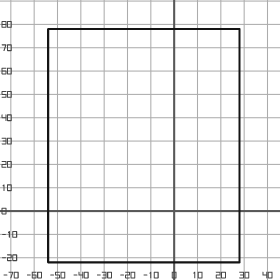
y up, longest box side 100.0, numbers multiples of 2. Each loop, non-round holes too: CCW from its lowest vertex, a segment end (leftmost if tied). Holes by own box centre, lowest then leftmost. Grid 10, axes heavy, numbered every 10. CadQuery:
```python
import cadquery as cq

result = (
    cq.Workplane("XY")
    .moveTo(-54.0, -22.0)
    .lineTo(28.0, -22.0)
    .lineTo(28.0, 78.0)
    .lineTo(-54.0, 78.0)
    .close()
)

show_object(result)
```